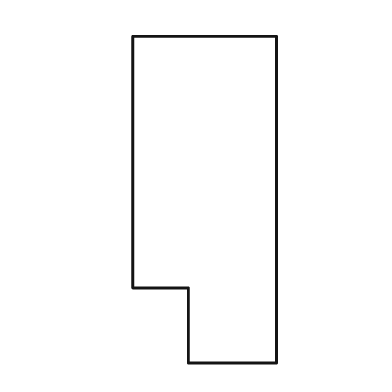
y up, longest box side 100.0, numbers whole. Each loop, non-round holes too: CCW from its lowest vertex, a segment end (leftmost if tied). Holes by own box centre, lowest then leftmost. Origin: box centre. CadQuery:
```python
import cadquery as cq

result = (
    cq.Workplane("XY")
    .moveTo(-5.0, -50.0)
    .lineTo(22.0, -50.0)
    .lineTo(22.0, 50.0)
    .lineTo(-22.0, 50.0)
    .lineTo(-22.0, -27.0)
    .lineTo(-5.0, -27.0)
    .close()
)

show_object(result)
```